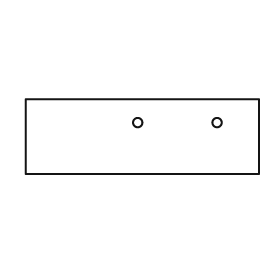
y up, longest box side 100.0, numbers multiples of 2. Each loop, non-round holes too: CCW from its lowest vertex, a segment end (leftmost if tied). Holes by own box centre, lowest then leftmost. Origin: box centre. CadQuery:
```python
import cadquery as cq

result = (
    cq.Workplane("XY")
    .moveTo(-50.0, -16.0)
    .lineTo(50.0, -16.0)
    .lineTo(50.0, 16.0)
    .lineTo(-50.0, 16.0)
    .close()
    .moveTo(-2.0, 6.0)
    .circle(2.0)
    .moveTo(32.0, 6.0)
    .circle(2.0)
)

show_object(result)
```